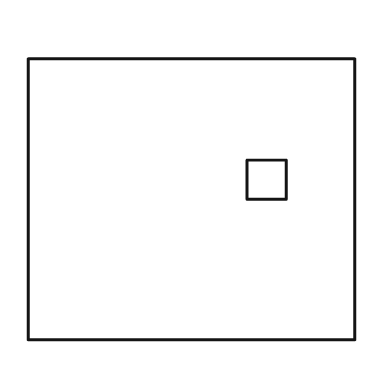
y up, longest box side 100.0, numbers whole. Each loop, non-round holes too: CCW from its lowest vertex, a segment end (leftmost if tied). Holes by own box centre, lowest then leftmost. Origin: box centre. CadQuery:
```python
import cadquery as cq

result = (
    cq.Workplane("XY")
    .moveTo(-50.0, -43.0)
    .lineTo(50.0, -43.0)
    .lineTo(50.0, 43.0)
    .lineTo(-50.0, 43.0)
    .close()
    .moveTo(17.0, 0.0)
    .lineTo(29.0, 0.0)
    .lineTo(29.0, 12.0)
    .lineTo(17.0, 12.0)
    .close()
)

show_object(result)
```